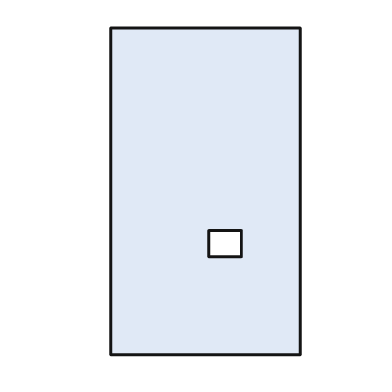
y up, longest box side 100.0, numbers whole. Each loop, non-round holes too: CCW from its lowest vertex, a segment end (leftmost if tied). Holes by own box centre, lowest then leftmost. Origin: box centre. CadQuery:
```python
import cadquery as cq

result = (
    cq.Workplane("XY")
    .moveTo(-29.0, -50.0)
    .lineTo(29.0, -50.0)
    .lineTo(29.0, 50.0)
    .lineTo(-29.0, 50.0)
    .close()
    .moveTo(1.0, -20.0)
    .lineTo(11.0, -20.0)
    .lineTo(11.0, -12.0)
    .lineTo(1.0, -12.0)
    .close()
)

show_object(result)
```